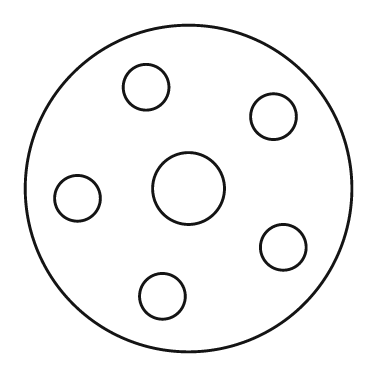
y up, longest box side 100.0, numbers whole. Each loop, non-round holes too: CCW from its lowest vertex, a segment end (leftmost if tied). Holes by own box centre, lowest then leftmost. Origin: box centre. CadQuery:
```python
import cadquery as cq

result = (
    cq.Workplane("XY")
    .moveTo(0.0, 0.0)
    .circle(50.0)
    .moveTo(-8.0, -33.0)
    .circle(7.0)
    .moveTo(29.0, -18.0)
    .circle(7.0)
    .moveTo(-34.0, -3.0)
    .circle(7.0)
    .moveTo(0.0, 0.0)
    .circle(11.0)
    .moveTo(26.0, 22.0)
    .circle(7.0)
    .moveTo(-13.0, 31.0)
    .circle(7.0)
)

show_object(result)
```